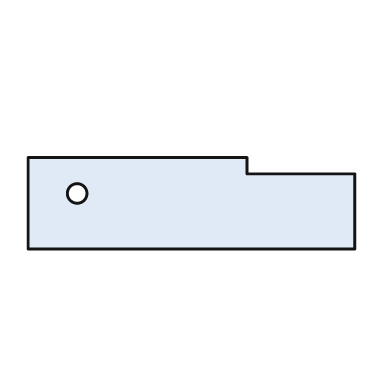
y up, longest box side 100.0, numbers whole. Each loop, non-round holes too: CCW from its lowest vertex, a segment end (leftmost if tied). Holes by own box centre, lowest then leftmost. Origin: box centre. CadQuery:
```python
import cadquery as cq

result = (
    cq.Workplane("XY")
    .moveTo(-50.0, -14.0)
    .lineTo(50.0, -14.0)
    .lineTo(50.0, 9.0)
    .lineTo(17.0, 9.0)
    .lineTo(17.0, 14.0)
    .lineTo(-50.0, 14.0)
    .close()
    .moveTo(-35.0, 3.0)
    .circle(3.0)
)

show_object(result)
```